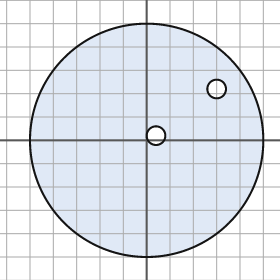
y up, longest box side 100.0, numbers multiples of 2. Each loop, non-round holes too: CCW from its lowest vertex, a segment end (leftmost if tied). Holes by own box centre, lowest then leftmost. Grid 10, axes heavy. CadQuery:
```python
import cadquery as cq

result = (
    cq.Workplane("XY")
    .moveTo(0.0, 0.0)
    .circle(50.0)
    .moveTo(4.0, 2.0)
    .circle(4.0)
    .moveTo(30.0, 22.0)
    .circle(4.0)
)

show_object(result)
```